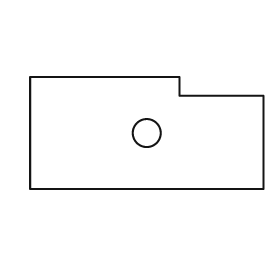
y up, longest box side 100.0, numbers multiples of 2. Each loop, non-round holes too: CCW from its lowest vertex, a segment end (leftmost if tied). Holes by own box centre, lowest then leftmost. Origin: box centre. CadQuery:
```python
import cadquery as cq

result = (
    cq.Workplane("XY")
    .moveTo(-50.0, -24.0)
    .lineTo(50.0, -24.0)
    .lineTo(50.0, 16.0)
    .lineTo(14.0, 16.0)
    .lineTo(14.0, 24.0)
    .lineTo(-50.0, 24.0)
    .close()
    .moveTo(0.0, 0.0)
    .circle(6.0)
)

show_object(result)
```